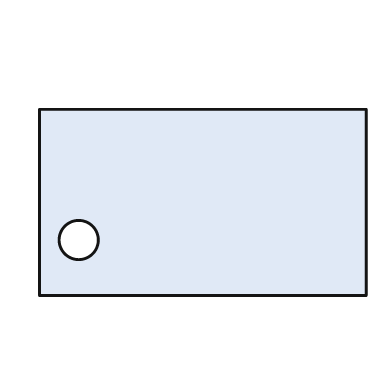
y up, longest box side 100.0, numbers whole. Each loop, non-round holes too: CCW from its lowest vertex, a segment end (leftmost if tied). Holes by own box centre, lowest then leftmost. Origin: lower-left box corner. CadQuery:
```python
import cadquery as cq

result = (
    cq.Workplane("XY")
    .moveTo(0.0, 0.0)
    .lineTo(100.0, 0.0)
    .lineTo(100.0, 57.0)
    .lineTo(0.0, 57.0)
    .close()
    .moveTo(12.0, 17.0)
    .circle(6.0)
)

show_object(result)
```